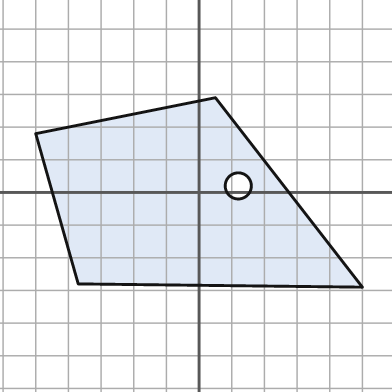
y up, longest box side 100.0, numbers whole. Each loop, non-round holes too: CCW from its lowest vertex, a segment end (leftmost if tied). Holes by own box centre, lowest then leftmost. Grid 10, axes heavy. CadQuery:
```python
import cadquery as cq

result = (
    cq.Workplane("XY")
    .moveTo(50.0, -29.0)
    .lineTo(5.0, 29.0)
    .lineTo(-50.0, 18.0)
    .lineTo(-37.0, -28.0)
    .close()
    .moveTo(12.0, 2.0)
    .circle(4.0)
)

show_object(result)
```